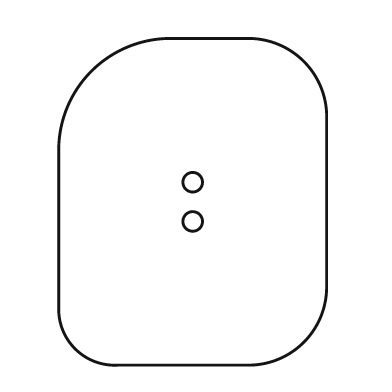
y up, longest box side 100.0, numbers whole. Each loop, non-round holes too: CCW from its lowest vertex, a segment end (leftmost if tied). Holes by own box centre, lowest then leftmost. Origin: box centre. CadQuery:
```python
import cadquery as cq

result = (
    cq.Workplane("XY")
    .moveTo(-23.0, -50.0)
    .lineTo(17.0, -50.0)
    .threePointArc((34.0, -43.0), (41.0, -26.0))
    .lineTo(41.0, 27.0)
    .threePointArc((34.0, 43.0), (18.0, 50.0))
    .lineTo(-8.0, 50.0)
    .threePointArc((-31.0, 40.0), (-41.0, 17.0))
    .lineTo(-41.0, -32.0)
    .threePointArc((-36.0, -45.0), (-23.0, -50.0))
    .close()
    .moveTo(0.0, -6.0)
    .circle(3.0)
    .moveTo(0.0, 6.0)
    .circle(3.0)
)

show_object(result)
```